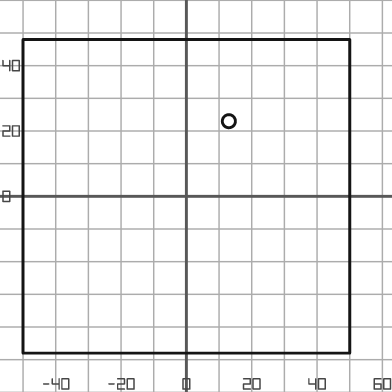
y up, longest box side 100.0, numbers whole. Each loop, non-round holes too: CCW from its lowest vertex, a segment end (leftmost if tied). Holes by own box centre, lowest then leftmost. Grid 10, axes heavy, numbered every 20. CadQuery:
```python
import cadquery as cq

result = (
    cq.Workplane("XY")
    .moveTo(-50.0, -48.0)
    .lineTo(50.0, -48.0)
    .lineTo(50.0, 48.0)
    .lineTo(-50.0, 48.0)
    .close()
    .moveTo(13.0, 23.0)
    .circle(2.0)
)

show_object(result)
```